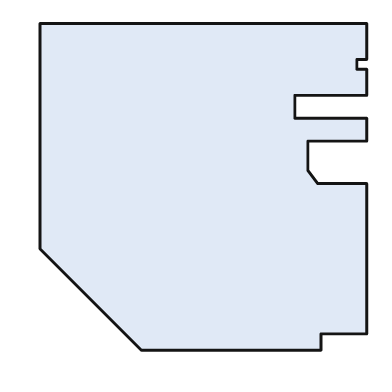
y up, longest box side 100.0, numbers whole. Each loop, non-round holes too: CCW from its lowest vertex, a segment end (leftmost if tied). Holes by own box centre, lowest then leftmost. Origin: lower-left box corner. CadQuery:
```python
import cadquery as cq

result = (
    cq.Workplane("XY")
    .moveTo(31.0, 0.0)
    .lineTo(86.0, 0.0)
    .lineTo(86.0, 5.0)
    .lineTo(100.0, 5.0)
    .lineTo(100.0, 51.0)
    .lineTo(85.0, 51.0)
    .lineTo(82.0, 55.0)
    .lineTo(82.0, 64.0)
    .lineTo(100.0, 64.0)
    .lineTo(100.0, 71.0)
    .lineTo(78.0, 71.0)
    .lineTo(78.0, 78.0)
    .lineTo(100.0, 78.0)
    .lineTo(100.0, 86.0)
    .lineTo(97.0, 86.0)
    .lineTo(97.0, 89.0)
    .lineTo(100.0, 89.0)
    .lineTo(100.0, 100.0)
    .lineTo(0.0, 100.0)
    .lineTo(0.0, 31.0)
    .close()
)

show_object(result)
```